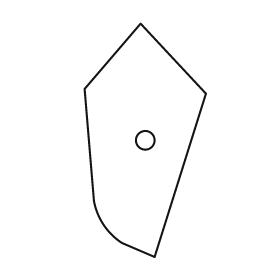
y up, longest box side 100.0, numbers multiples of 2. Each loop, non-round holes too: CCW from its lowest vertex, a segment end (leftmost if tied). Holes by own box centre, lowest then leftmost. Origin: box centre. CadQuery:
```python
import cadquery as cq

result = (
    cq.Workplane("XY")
    .moveTo(4.0, -50.0)
    .lineTo(26.0, 20.0)
    .lineTo(-2.0, 50.0)
    .lineTo(-26.0, 22.0)
    .lineTo(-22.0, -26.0)
    .threePointArc((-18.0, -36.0), (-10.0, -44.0))
    .close()
    .moveTo(0.0, 0.0)
    .circle(4.0)
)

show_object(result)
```